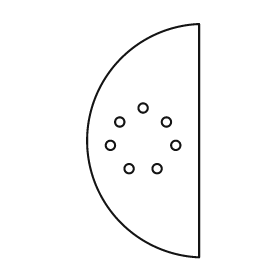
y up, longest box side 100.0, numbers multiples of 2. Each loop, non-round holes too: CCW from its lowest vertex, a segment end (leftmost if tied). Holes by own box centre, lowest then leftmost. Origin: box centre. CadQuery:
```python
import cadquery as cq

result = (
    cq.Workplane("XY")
    .moveTo(24.0, -50.0)
    .lineTo(24.0, 50.0)
    .threePointArc((-24.0, 0.0), (24.0, -50.0))
    .close()
    .moveTo(-6.0, -12.0)
    .circle(2.0)
    .moveTo(6.0, -12.0)
    .circle(2.0)
    .moveTo(-14.0, -2.0)
    .circle(2.0)
    .moveTo(14.0, -2.0)
    .circle(2.0)
    .moveTo(-10.0, 8.0)
    .circle(2.0)
    .moveTo(10.0, 8.0)
    .circle(2.0)
    .moveTo(0.0, 14.0)
    .circle(2.0)
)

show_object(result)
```